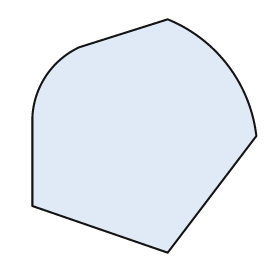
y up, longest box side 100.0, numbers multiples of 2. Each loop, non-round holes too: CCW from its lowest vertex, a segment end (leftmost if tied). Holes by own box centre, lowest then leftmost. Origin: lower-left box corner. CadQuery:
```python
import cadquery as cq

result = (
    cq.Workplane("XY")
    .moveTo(58.0, 0.0)
    .lineTo(96.0, 50.0)
    .threePointArc((84.0, 80.0), (58.0, 100.0))
    .lineTo(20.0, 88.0)
    .threePointArc((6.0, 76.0), (0.0, 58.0))
    .lineTo(0.0, 20.0)
    .close()
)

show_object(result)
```